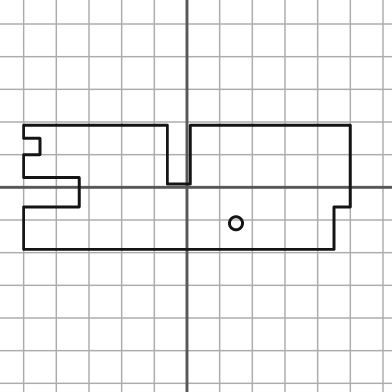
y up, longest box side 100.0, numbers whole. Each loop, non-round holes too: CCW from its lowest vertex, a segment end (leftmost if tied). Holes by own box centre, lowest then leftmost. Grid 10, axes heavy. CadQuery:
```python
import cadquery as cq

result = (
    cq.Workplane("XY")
    .moveTo(-50.0, -19.0)
    .lineTo(45.0, -19.0)
    .lineTo(45.0, -6.0)
    .lineTo(50.0, -6.0)
    .lineTo(50.0, 19.0)
    .lineTo(1.0, 19.0)
    .lineTo(1.0, 1.0)
    .lineTo(-6.0, 1.0)
    .lineTo(-6.0, 19.0)
    .lineTo(-50.0, 19.0)
    .lineTo(-50.0, 15.0)
    .lineTo(-45.0, 15.0)
    .lineTo(-45.0, 10.0)
    .lineTo(-50.0, 10.0)
    .lineTo(-50.0, 3.0)
    .lineTo(-33.0, 3.0)
    .lineTo(-33.0, -6.0)
    .lineTo(-50.0, -6.0)
    .close()
    .moveTo(15.0, -11.0)
    .circle(2.0)
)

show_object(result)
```